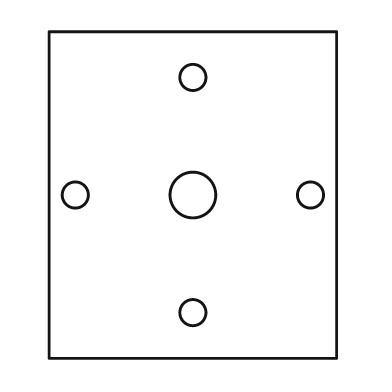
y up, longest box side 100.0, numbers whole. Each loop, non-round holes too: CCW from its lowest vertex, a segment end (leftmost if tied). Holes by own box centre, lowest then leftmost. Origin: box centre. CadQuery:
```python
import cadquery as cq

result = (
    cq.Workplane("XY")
    .moveTo(-44.0, -50.0)
    .lineTo(44.0, -50.0)
    .lineTo(44.0, 50.0)
    .lineTo(-44.0, 50.0)
    .close()
    .moveTo(0.0, -36.0)
    .circle(4.0)
    .moveTo(-36.0, 0.0)
    .circle(4.0)
    .moveTo(0.0, 0.0)
    .circle(7.0)
    .moveTo(36.0, 0.0)
    .circle(4.0)
    .moveTo(0.0, 36.0)
    .circle(4.0)
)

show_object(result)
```